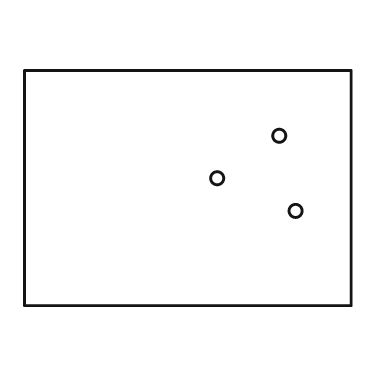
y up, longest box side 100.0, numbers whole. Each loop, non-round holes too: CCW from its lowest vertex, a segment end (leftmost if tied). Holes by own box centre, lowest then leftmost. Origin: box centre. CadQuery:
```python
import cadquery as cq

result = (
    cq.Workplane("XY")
    .moveTo(-50.0, -36.0)
    .lineTo(50.0, -36.0)
    .lineTo(50.0, 36.0)
    .lineTo(-50.0, 36.0)
    .close()
    .moveTo(33.0, -7.0)
    .circle(2.0)
    .moveTo(9.0, 3.0)
    .circle(2.0)
    .moveTo(28.0, 16.0)
    .circle(2.0)
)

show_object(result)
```